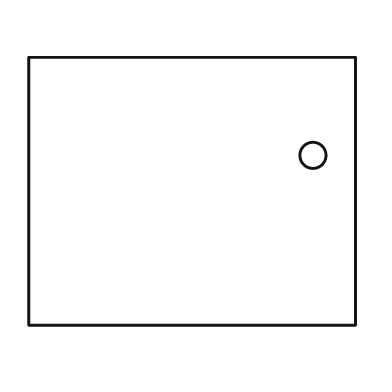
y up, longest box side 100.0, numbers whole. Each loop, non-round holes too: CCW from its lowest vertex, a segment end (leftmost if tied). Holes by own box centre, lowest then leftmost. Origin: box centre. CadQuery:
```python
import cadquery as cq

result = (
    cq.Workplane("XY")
    .moveTo(-50.0, -41.0)
    .lineTo(50.0, -41.0)
    .lineTo(50.0, 41.0)
    .lineTo(-50.0, 41.0)
    .close()
    .moveTo(37.0, 11.0)
    .circle(4.0)
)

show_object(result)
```